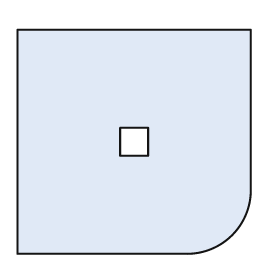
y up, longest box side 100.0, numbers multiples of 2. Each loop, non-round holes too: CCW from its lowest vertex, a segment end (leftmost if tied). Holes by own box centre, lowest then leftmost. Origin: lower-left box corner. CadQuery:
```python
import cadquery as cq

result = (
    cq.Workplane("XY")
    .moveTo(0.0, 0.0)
    .lineTo(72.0, 0.0)
    .threePointArc((92.0, 8.0), (100.0, 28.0))
    .lineTo(100.0, 96.0)
    .lineTo(0.0, 96.0)
    .close()
    .moveTo(44.0, 42.0)
    .lineTo(56.0, 42.0)
    .lineTo(56.0, 54.0)
    .lineTo(44.0, 54.0)
    .close()
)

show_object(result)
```